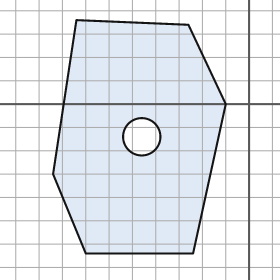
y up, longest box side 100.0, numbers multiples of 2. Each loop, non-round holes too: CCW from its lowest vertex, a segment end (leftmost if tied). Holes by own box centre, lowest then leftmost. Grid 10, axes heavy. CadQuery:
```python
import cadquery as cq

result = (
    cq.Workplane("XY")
    .moveTo(-70.0, -64.0)
    .lineTo(-24.0, -64.0)
    .lineTo(-10.0, 0.0)
    .lineTo(-26.0, 34.0)
    .lineTo(-74.0, 36.0)
    .lineTo(-84.0, -30.0)
    .close()
    .moveTo(-46.0, -14.0)
    .circle(8.0)
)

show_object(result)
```